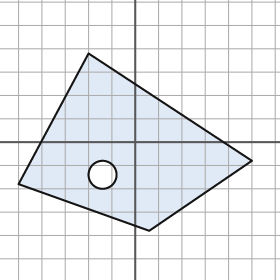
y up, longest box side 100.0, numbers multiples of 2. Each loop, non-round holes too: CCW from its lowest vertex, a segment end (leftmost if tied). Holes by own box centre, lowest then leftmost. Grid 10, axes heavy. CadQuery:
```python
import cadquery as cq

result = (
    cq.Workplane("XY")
    .moveTo(6.0, -38.0)
    .lineTo(50.0, -8.0)
    .lineTo(-20.0, 38.0)
    .lineTo(-50.0, -18.0)
    .close()
    .moveTo(-14.0, -14.0)
    .circle(6.0)
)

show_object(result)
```